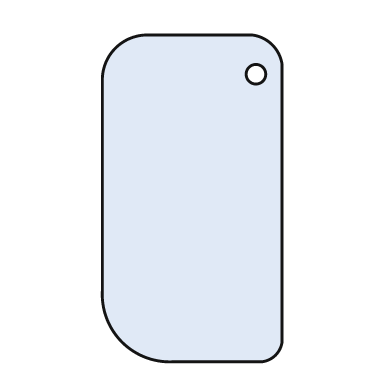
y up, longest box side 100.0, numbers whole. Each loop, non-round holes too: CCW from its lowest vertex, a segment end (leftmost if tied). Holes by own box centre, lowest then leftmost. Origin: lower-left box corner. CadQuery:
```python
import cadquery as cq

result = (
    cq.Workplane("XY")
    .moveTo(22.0, 0.0)
    .lineTo(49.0, 0.0)
    .threePointArc((53.0, 2.0), (55.0, 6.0))
    .lineTo(55.0, 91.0)
    .threePointArc((52.0, 97.0), (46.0, 100.0))
    .lineTo(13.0, 100.0)
    .threePointArc((4.0, 96.0), (0.0, 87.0))
    .lineTo(0.0, 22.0)
    .threePointArc((6.0, 6.0), (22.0, 0.0))
    .close()
    .moveTo(47.0, 88.0)
    .circle(3.0)
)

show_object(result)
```